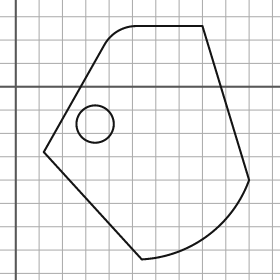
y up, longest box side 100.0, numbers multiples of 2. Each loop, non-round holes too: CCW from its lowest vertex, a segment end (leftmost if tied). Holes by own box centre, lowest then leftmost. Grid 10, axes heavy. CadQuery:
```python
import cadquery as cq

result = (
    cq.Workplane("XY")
    .moveTo(54.0, -74.0)
    .threePointArc((82.0, -64.0), (100.0, -40.0))
    .lineTo(80.0, 26.0)
    .lineTo(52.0, 26.0)
    .threePointArc((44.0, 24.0), (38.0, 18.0))
    .lineTo(12.0, -28.0)
    .close()
    .moveTo(34.0, -16.0)
    .circle(8.0)
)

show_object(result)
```